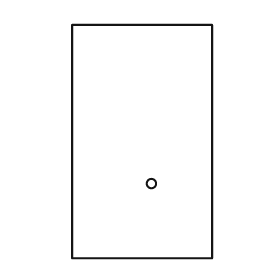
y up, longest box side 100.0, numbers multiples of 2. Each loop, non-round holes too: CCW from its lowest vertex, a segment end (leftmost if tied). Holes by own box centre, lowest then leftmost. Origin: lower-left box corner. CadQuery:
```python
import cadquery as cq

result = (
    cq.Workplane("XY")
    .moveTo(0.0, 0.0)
    .lineTo(60.0, 0.0)
    .lineTo(60.0, 100.0)
    .lineTo(0.0, 100.0)
    .close()
    .moveTo(34.0, 32.0)
    .circle(2.0)
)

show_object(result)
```